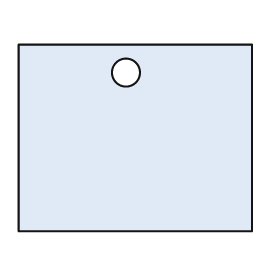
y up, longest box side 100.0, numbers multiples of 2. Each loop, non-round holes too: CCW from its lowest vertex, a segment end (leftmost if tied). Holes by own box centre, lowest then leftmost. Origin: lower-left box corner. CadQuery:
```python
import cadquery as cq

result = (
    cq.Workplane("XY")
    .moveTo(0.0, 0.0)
    .lineTo(100.0, 0.0)
    .lineTo(100.0, 80.0)
    .lineTo(0.0, 80.0)
    .close()
    .moveTo(46.0, 68.0)
    .circle(6.0)
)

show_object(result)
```